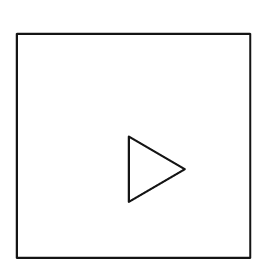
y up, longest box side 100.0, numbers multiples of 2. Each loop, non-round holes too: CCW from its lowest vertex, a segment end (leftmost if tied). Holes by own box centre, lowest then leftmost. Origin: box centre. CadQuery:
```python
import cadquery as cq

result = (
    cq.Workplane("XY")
    .moveTo(-50.0, -48.0)
    .lineTo(50.0, -48.0)
    .lineTo(50.0, 48.0)
    .lineTo(-50.0, 48.0)
    .close()
    .moveTo(-2.0, -24.0)
    .lineTo(22.0, -10.0)
    .lineTo(-2.0, 4.0)
    .close()
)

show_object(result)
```